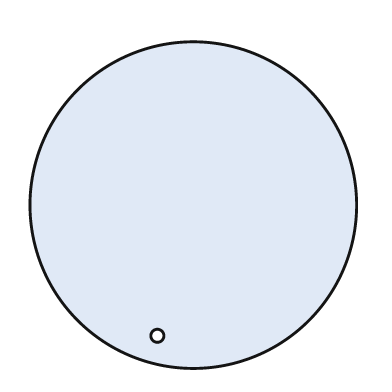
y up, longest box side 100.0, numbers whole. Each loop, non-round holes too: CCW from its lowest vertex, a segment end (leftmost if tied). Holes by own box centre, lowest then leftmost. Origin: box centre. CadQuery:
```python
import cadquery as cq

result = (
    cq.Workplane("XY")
    .moveTo(0.0, 0.0)
    .circle(50.0)
    .moveTo(-11.0, -40.0)
    .circle(2.0)
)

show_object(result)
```